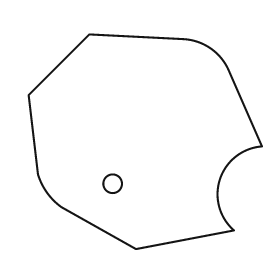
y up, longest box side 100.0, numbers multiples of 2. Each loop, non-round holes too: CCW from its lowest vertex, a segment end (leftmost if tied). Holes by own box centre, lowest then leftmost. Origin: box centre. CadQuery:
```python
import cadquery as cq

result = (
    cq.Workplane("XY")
    .moveTo(-4.0, -46.0)
    .lineTo(38.0, -38.0)
    .threePointArc((32.0, -16.0), (50.0, -2.0))
    .lineTo(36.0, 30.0)
    .threePointArc((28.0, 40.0), (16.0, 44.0))
    .lineTo(-24.0, 46.0)
    .lineTo(-50.0, 20.0)
    .lineTo(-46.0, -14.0)
    .threePointArc((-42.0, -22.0), (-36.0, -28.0))
    .close()
    .moveTo(-14.0, -18.0)
    .circle(4.0)
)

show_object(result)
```